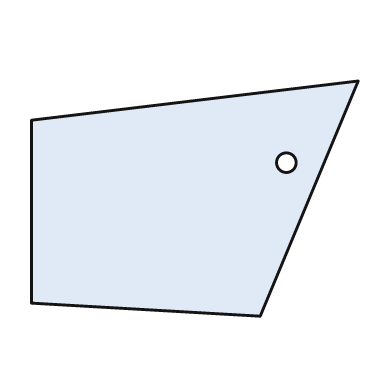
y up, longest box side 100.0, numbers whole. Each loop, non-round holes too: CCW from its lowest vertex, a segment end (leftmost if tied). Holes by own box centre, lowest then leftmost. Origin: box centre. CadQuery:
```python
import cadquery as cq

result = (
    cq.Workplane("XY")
    .moveTo(20.0, -36.0)
    .lineTo(50.0, 36.0)
    .lineTo(-50.0, 24.0)
    .lineTo(-50.0, -32.0)
    .close()
    .moveTo(28.0, 11.0)
    .circle(3.0)
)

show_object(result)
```